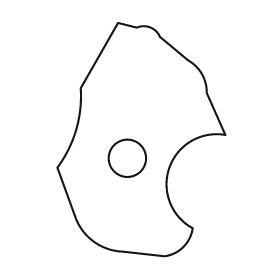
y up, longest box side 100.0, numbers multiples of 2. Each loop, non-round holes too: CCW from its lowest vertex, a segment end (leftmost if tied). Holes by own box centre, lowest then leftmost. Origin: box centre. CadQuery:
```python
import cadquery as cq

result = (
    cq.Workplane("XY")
    .moveTo(10.0, -50.0)
    .threePointArc((18.0, -46.0), (22.0, -38.0))
    .threePointArc((12.0, -12.0), (36.0, 2.0))
    .lineTo(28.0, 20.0)
    .threePointArc((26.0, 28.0), (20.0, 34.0))
    .lineTo(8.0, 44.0)
    .threePointArc((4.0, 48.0), (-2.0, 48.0))
    .lineTo(-10.0, 50.0)
    .lineTo(-26.0, 22.0)
    .threePointArc((-28.0, 4.0), (-36.0, -12.0))
    .lineTo(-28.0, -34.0)
    .threePointArc((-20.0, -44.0), (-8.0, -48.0))
    .close()
    .moveTo(-6.0, -8.0)
    .circle(8.0)
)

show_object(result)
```